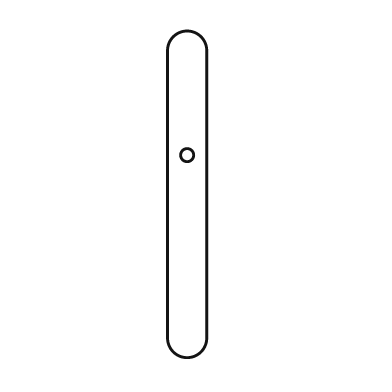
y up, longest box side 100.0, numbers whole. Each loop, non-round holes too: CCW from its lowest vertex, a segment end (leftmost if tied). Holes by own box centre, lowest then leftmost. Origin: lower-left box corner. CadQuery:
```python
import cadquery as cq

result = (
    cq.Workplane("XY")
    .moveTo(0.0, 6.0)
    .threePointArc((6.0, 0.0), (12.0, 6.0))
    .lineTo(12.0, 94.0)
    .threePointArc((6.0, 100.0), (0.0, 94.0))
    .close()
    .moveTo(6.0, 62.0)
    .circle(2.0)
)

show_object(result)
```